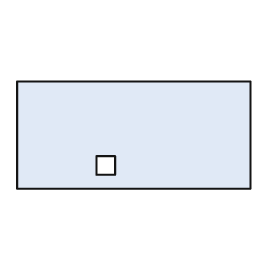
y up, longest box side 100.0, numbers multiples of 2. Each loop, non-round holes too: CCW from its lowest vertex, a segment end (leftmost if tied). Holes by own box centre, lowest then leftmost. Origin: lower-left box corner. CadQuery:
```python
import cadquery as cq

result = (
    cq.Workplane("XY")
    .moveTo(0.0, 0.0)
    .lineTo(100.0, 0.0)
    .lineTo(100.0, 46.0)
    .lineTo(0.0, 46.0)
    .close()
    .moveTo(34.0, 6.0)
    .lineTo(42.0, 6.0)
    .lineTo(42.0, 14.0)
    .lineTo(34.0, 14.0)
    .close()
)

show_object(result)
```